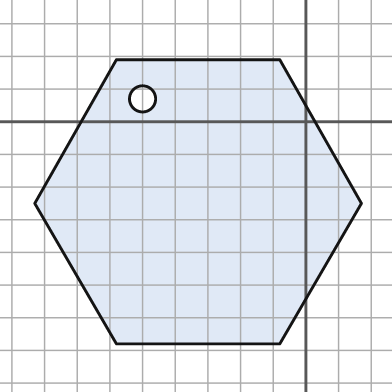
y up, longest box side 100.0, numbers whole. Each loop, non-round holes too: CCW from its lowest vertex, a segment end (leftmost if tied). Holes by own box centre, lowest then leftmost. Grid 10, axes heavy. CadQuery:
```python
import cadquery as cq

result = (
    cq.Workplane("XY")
    .moveTo(-58.0, -68.0)
    .lineTo(-8.0, -68.0)
    .lineTo(17.0, -25.0)
    .lineTo(-8.0, 19.0)
    .lineTo(-58.0, 19.0)
    .lineTo(-83.0, -25.0)
    .close()
    .moveTo(-50.0, 7.0)
    .circle(4.0)
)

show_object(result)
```